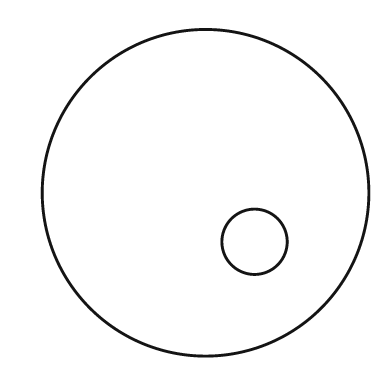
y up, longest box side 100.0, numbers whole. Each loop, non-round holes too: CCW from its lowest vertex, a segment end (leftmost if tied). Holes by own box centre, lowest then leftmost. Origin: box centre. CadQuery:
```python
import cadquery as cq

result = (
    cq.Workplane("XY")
    .moveTo(0.0, 0.0)
    .circle(50.0)
    .moveTo(15.0, -15.0)
    .circle(10.0)
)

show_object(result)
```